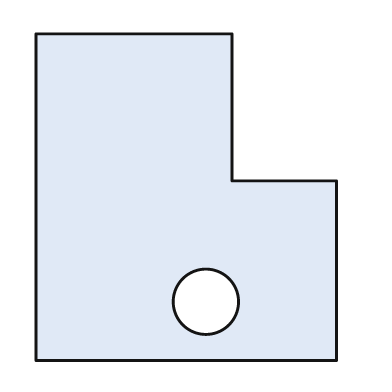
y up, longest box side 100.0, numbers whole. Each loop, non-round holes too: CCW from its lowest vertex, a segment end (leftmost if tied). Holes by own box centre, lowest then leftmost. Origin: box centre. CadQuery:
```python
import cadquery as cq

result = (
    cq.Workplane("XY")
    .moveTo(-46.0, -50.0)
    .lineTo(46.0, -50.0)
    .lineTo(46.0, 5.0)
    .lineTo(14.0, 5.0)
    .lineTo(14.0, 50.0)
    .lineTo(-46.0, 50.0)
    .close()
    .moveTo(6.0, -32.0)
    .circle(10.0)
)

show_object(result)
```